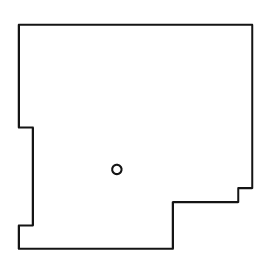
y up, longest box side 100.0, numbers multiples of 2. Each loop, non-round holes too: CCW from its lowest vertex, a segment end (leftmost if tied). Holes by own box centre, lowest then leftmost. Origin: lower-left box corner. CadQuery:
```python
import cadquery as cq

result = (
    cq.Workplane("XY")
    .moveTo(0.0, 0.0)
    .lineTo(66.0, 0.0)
    .lineTo(66.0, 20.0)
    .lineTo(94.0, 20.0)
    .lineTo(94.0, 26.0)
    .lineTo(100.0, 26.0)
    .lineTo(100.0, 96.0)
    .lineTo(0.0, 96.0)
    .lineTo(0.0, 52.0)
    .lineTo(6.0, 52.0)
    .lineTo(6.0, 10.0)
    .lineTo(0.0, 10.0)
    .close()
    .moveTo(42.0, 34.0)
    .circle(2.0)
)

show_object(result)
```